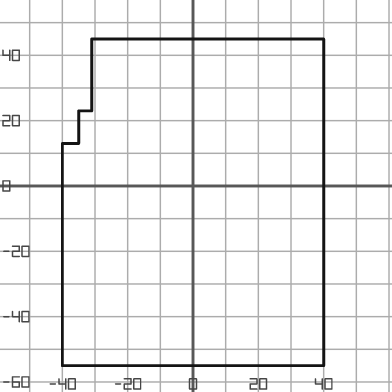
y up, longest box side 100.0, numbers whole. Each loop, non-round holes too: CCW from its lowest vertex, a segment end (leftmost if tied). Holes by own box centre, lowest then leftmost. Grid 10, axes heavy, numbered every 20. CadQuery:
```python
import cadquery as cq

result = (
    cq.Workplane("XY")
    .moveTo(-40.0, -55.0)
    .lineTo(40.0, -55.0)
    .lineTo(40.0, 45.0)
    .lineTo(-31.0, 45.0)
    .lineTo(-31.0, 23.0)
    .lineTo(-35.0, 23.0)
    .lineTo(-35.0, 13.0)
    .lineTo(-40.0, 13.0)
    .close()
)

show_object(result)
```